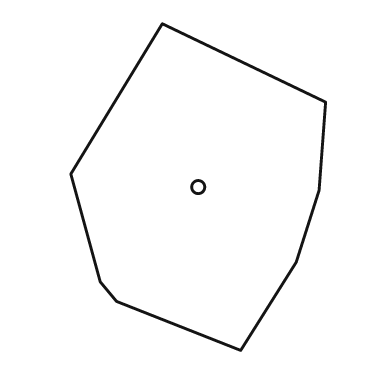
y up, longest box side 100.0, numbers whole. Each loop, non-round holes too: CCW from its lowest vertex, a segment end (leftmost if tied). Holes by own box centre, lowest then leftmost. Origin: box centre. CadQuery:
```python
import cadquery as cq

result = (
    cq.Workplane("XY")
    .moveTo(13.0, -50.0)
    .lineTo(30.0, -23.0)
    .lineTo(37.0, -1.0)
    .lineTo(39.0, 26.0)
    .lineTo(-11.0, 50.0)
    .lineTo(-39.0, 4.0)
    .lineTo(-30.0, -29.0)
    .lineTo(-25.0, -35.0)
    .close()
    .moveTo(0.0, 0.0)
    .circle(2.0)
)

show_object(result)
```